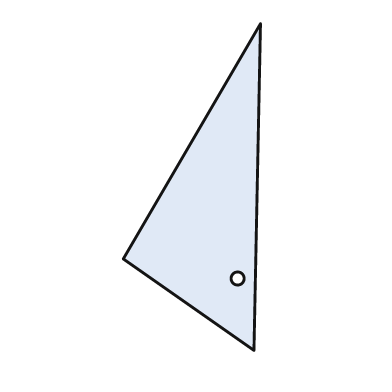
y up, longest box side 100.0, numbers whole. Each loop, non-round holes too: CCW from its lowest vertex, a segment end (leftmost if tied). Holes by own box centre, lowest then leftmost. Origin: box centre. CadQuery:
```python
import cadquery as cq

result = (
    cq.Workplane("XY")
    .moveTo(19.0, -50.0)
    .lineTo(21.0, 50.0)
    .lineTo(-21.0, -22.0)
    .close()
    .moveTo(14.0, -28.0)
    .circle(2.0)
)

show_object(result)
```